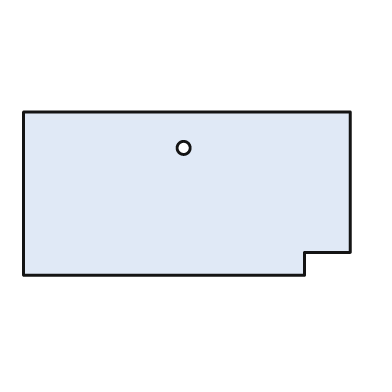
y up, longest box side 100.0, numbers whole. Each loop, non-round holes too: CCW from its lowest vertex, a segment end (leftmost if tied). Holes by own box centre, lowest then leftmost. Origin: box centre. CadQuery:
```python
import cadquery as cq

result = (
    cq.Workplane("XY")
    .moveTo(-50.0, -25.0)
    .lineTo(36.0, -25.0)
    .lineTo(36.0, -18.0)
    .lineTo(50.0, -18.0)
    .lineTo(50.0, 25.0)
    .lineTo(-50.0, 25.0)
    .close()
    .moveTo(-1.0, 14.0)
    .circle(2.0)
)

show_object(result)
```